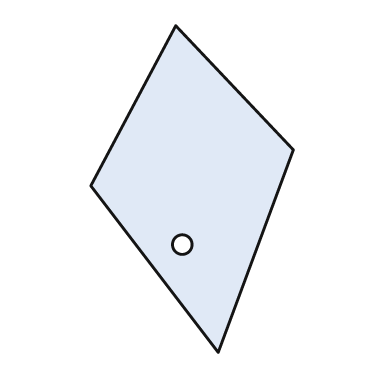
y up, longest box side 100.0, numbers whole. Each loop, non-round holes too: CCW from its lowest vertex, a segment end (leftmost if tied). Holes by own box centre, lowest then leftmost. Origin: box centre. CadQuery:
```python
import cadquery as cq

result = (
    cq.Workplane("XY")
    .moveTo(8.0, -50.0)
    .lineTo(31.0, 12.0)
    .lineTo(-5.0, 50.0)
    .lineTo(-31.0, 1.0)
    .close()
    .moveTo(-3.0, -17.0)
    .circle(3.0)
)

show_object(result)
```